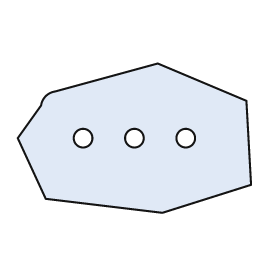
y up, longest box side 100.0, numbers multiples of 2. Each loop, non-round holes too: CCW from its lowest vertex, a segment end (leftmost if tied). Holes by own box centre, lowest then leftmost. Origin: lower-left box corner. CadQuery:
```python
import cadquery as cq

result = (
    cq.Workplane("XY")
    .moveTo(62.0, 0.0)
    .lineTo(100.0, 12.0)
    .lineTo(98.0, 48.0)
    .lineTo(60.0, 64.0)
    .lineTo(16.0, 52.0)
    .threePointArc((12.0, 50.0), (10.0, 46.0))
    .lineTo(0.0, 32.0)
    .lineTo(12.0, 6.0)
    .close()
    .moveTo(28.0, 32.0)
    .circle(4.0)
    .moveTo(50.0, 32.0)
    .circle(4.0)
    .moveTo(72.0, 32.0)
    .circle(4.0)
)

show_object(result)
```